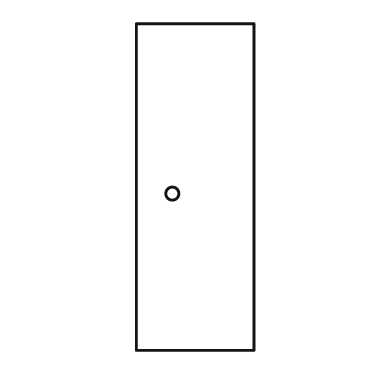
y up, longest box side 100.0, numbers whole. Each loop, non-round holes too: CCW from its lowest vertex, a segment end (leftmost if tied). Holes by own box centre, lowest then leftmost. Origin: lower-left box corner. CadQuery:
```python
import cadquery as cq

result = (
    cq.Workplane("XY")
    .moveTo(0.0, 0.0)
    .lineTo(36.0, 0.0)
    .lineTo(36.0, 100.0)
    .lineTo(0.0, 100.0)
    .close()
    .moveTo(11.0, 48.0)
    .circle(2.0)
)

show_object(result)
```